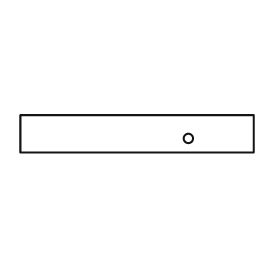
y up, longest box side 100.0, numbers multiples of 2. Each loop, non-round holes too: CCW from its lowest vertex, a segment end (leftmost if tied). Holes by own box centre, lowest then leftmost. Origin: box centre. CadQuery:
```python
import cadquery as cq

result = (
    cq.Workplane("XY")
    .moveTo(-50.0, -8.0)
    .lineTo(50.0, -8.0)
    .lineTo(50.0, 8.0)
    .lineTo(-50.0, 8.0)
    .close()
    .moveTo(22.0, -2.0)
    .circle(2.0)
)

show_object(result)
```